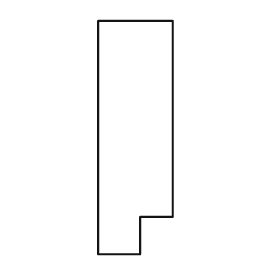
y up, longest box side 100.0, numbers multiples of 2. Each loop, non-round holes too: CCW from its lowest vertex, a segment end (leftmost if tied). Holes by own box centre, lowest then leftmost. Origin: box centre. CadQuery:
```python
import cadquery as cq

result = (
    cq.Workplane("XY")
    .moveTo(-16.0, -50.0)
    .lineTo(2.0, -50.0)
    .lineTo(2.0, -34.0)
    .lineTo(16.0, -34.0)
    .lineTo(16.0, 50.0)
    .lineTo(-16.0, 50.0)
    .close()
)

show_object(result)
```